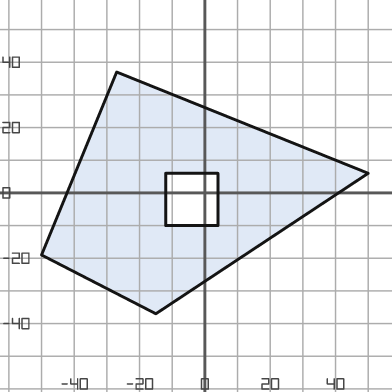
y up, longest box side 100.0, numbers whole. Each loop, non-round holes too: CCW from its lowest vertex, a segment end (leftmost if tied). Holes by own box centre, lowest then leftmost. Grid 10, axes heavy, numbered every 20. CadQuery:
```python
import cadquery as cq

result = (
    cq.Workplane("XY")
    .moveTo(-15.0, -37.0)
    .lineTo(50.0, 6.0)
    .lineTo(-27.0, 37.0)
    .lineTo(-50.0, -19.0)
    .close()
    .moveTo(-12.0, -10.0)
    .lineTo(4.0, -10.0)
    .lineTo(4.0, 6.0)
    .lineTo(-12.0, 6.0)
    .close()
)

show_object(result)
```